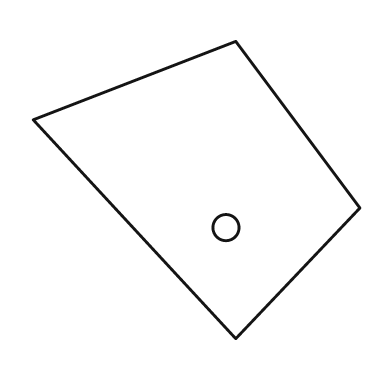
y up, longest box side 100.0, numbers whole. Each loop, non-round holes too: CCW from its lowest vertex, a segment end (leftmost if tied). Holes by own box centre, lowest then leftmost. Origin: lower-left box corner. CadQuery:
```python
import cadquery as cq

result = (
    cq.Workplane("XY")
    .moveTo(62.0, 0.0)
    .lineTo(100.0, 40.0)
    .lineTo(62.0, 91.0)
    .lineTo(0.0, 67.0)
    .close()
    .moveTo(59.0, 34.0)
    .circle(4.0)
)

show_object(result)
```